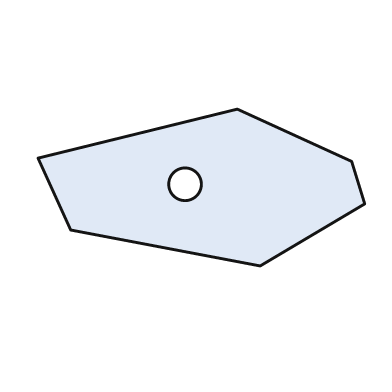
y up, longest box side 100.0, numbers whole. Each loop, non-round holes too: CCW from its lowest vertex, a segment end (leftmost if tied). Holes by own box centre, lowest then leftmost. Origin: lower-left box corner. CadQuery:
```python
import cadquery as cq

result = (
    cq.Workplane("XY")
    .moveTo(68.0, 0.0)
    .lineTo(100.0, 19.0)
    .lineTo(96.0, 32.0)
    .lineTo(61.0, 48.0)
    .lineTo(0.0, 33.0)
    .lineTo(10.0, 11.0)
    .close()
    .moveTo(45.0, 25.0)
    .circle(5.0)
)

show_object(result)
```